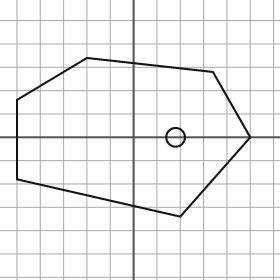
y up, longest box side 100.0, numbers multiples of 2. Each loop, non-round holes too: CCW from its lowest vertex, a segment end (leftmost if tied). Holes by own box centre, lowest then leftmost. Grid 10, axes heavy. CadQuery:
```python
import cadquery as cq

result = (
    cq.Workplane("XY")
    .moveTo(20.0, -34.0)
    .lineTo(50.0, 0.0)
    .lineTo(34.0, 28.0)
    .lineTo(-20.0, 34.0)
    .lineTo(-50.0, 16.0)
    .lineTo(-50.0, -18.0)
    .close()
    .moveTo(18.0, 0.0)
    .circle(4.0)
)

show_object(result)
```